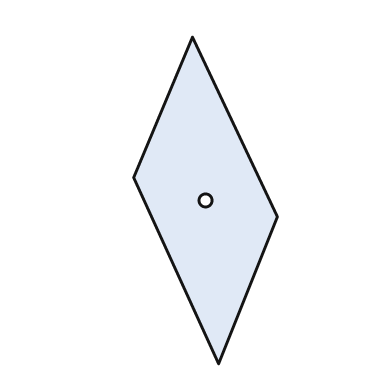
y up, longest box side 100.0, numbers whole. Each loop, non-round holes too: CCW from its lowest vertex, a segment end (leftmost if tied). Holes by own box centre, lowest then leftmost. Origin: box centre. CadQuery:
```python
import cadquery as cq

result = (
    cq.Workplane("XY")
    .moveTo(4.0, -50.0)
    .lineTo(22.0, -5.0)
    .lineTo(-4.0, 50.0)
    .lineTo(-22.0, 7.0)
    .close()
    .moveTo(0.0, 0.0)
    .circle(2.0)
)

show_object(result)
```